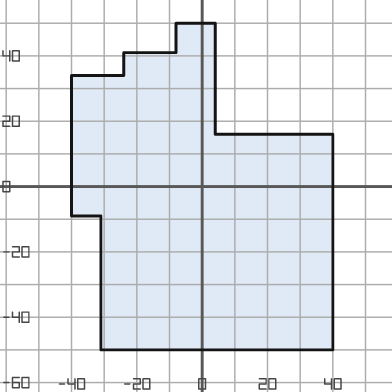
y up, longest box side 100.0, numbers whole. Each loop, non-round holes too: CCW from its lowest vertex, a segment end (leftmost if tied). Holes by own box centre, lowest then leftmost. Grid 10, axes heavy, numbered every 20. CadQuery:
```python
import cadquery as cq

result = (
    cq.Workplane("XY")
    .moveTo(-31.0, -50.0)
    .lineTo(40.0, -50.0)
    .lineTo(40.0, 16.0)
    .lineTo(4.0, 16.0)
    .lineTo(4.0, 50.0)
    .lineTo(-8.0, 50.0)
    .lineTo(-8.0, 41.0)
    .lineTo(-24.0, 41.0)
    .lineTo(-24.0, 34.0)
    .lineTo(-40.0, 34.0)
    .lineTo(-40.0, -9.0)
    .lineTo(-31.0, -9.0)
    .close()
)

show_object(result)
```